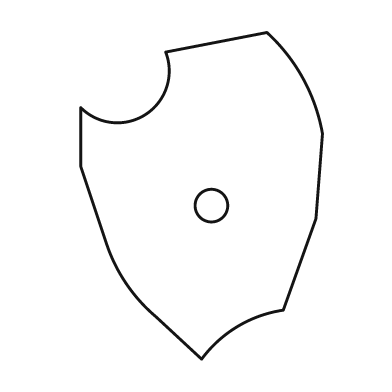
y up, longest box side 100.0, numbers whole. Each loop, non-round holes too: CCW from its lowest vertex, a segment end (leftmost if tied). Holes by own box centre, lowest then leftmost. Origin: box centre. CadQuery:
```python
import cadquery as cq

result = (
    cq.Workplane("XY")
    .moveTo(0.0, -50.0)
    .threePointArc((11.0, -40.0), (25.0, -35.0))
    .lineTo(35.0, -7.0)
    .lineTo(37.0, 19.0)
    .threePointArc((31.0, 36.0), (20.0, 50.0))
    .lineTo(-11.0, 44.0)
    .threePointArc((-17.0, 25.0), (-37.0, 27.0))
    .lineTo(-37.0, 9.0)
    .lineTo(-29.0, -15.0)
    .threePointArc((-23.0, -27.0), (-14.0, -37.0))
    .close()
    .moveTo(3.0, -3.0)
    .circle(5.0)
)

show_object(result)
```